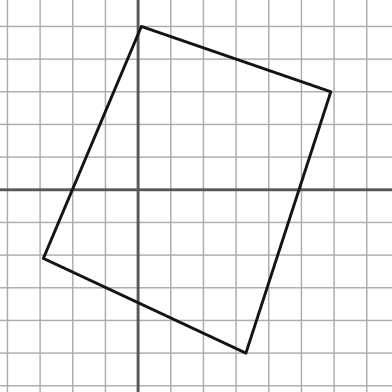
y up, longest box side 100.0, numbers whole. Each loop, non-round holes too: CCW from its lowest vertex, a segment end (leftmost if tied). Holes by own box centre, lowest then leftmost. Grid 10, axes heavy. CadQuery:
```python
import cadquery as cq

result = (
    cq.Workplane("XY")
    .moveTo(33.0, -50.0)
    .lineTo(59.0, 30.0)
    .lineTo(1.0, 50.0)
    .lineTo(-29.0, -21.0)
    .close()
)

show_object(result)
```